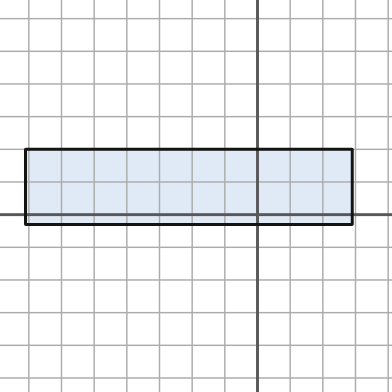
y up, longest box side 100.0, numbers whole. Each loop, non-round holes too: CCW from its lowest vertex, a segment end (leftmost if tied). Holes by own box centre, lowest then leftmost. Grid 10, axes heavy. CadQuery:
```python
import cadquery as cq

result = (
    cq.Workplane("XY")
    .moveTo(-71.0, -3.0)
    .lineTo(29.0, -3.0)
    .lineTo(29.0, 20.0)
    .lineTo(-71.0, 20.0)
    .close()
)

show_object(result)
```